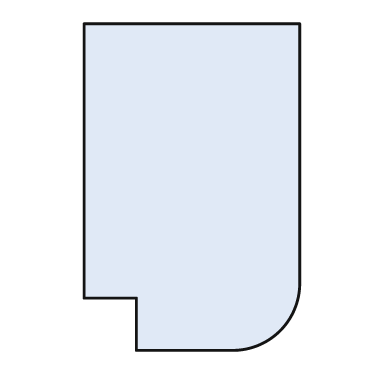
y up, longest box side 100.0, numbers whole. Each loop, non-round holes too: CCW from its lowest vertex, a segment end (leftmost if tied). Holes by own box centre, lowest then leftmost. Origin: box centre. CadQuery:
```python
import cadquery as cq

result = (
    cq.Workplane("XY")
    .moveTo(-17.0, -50.0)
    .lineTo(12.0, -50.0)
    .threePointArc((27.0, -44.0), (33.0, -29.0))
    .lineTo(33.0, 50.0)
    .lineTo(-33.0, 50.0)
    .lineTo(-33.0, -34.0)
    .lineTo(-17.0, -34.0)
    .close()
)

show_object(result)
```